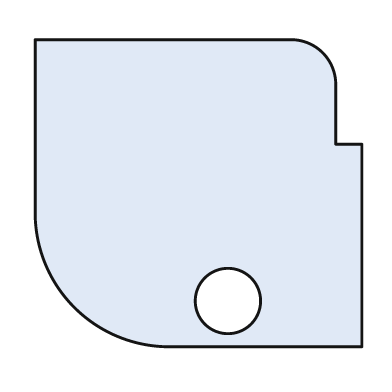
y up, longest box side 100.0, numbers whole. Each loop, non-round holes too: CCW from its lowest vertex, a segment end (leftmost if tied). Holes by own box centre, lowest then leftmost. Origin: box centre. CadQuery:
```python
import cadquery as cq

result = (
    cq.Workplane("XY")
    .moveTo(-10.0, -47.0)
    .lineTo(50.0, -47.0)
    .lineTo(50.0, 15.0)
    .lineTo(42.0, 15.0)
    .lineTo(42.0, 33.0)
    .threePointArc((38.0, 43.0), (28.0, 47.0))
    .lineTo(-50.0, 47.0)
    .lineTo(-50.0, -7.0)
    .threePointArc((-38.0, -35.0), (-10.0, -47.0))
    .close()
    .moveTo(9.0, -33.0)
    .circle(10.0)
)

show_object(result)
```